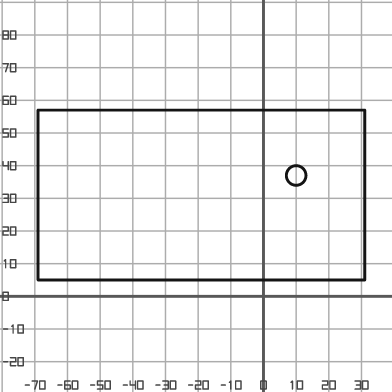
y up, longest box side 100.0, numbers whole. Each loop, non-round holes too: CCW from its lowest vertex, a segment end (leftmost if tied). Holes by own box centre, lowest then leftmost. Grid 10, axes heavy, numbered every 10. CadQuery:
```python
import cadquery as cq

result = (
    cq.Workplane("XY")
    .moveTo(-69.0, 5.0)
    .lineTo(31.0, 5.0)
    .lineTo(31.0, 57.0)
    .lineTo(-69.0, 57.0)
    .close()
    .moveTo(10.0, 37.0)
    .circle(3.0)
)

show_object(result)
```